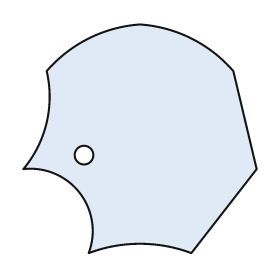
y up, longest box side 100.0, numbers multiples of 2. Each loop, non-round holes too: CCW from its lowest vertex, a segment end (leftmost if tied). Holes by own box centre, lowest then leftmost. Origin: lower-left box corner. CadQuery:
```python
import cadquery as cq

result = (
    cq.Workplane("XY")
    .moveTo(28.0, 0.0)
    .threePointArc((50.0, 4.0), (72.0, 0.0))
    .lineTo(100.0, 36.0)
    .lineTo(90.0, 78.0)
    .threePointArc((72.0, 92.0), (50.0, 98.0))
    .threePointArc((28.0, 92.0), (10.0, 78.0))
    .threePointArc((10.0, 56.0), (0.0, 36.0))
    .threePointArc((24.0, 26.0), (28.0, 0.0))
    .close()
    .moveTo(26.0, 42.0)
    .circle(4.0)
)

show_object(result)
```